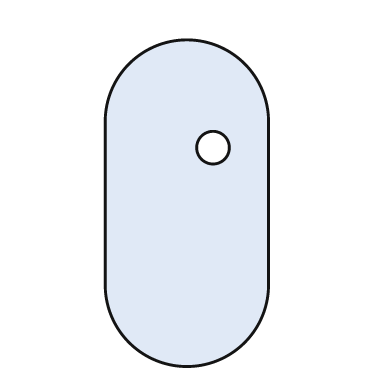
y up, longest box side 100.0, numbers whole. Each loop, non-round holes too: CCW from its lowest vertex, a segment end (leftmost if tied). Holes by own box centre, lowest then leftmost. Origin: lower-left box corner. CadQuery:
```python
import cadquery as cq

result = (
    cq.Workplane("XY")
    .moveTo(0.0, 25.0)
    .threePointArc((25.0, 0.0), (50.0, 25.0))
    .lineTo(50.0, 75.0)
    .threePointArc((25.0, 100.0), (0.0, 75.0))
    .close()
    .moveTo(33.0, 67.0)
    .circle(5.0)
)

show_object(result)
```